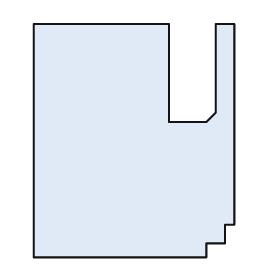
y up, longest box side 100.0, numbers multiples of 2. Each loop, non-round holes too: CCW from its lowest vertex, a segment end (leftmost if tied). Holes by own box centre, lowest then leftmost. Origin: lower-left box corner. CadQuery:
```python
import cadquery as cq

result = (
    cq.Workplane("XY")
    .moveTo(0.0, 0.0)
    .lineTo(74.0, 0.0)
    .lineTo(74.0, 6.0)
    .lineTo(82.0, 6.0)
    .lineTo(82.0, 14.0)
    .lineTo(86.0, 14.0)
    .lineTo(86.0, 100.0)
    .lineTo(78.0, 100.0)
    .lineTo(78.0, 62.0)
    .lineTo(74.0, 58.0)
    .lineTo(58.0, 58.0)
    .lineTo(58.0, 100.0)
    .lineTo(0.0, 100.0)
    .close()
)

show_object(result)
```